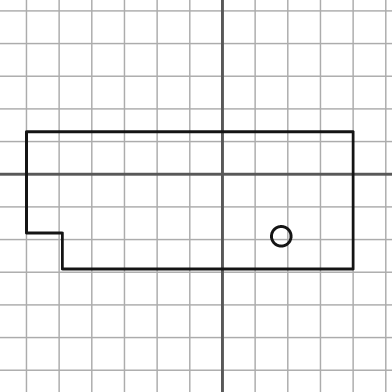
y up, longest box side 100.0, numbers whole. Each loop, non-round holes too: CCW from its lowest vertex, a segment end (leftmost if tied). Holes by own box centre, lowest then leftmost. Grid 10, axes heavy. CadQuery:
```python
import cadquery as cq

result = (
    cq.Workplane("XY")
    .moveTo(-49.0, -29.0)
    .lineTo(40.0, -29.0)
    .lineTo(40.0, 13.0)
    .lineTo(-60.0, 13.0)
    .lineTo(-60.0, -18.0)
    .lineTo(-49.0, -18.0)
    .close()
    .moveTo(18.0, -19.0)
    .circle(3.0)
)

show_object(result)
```